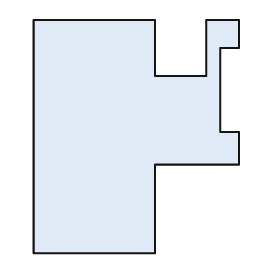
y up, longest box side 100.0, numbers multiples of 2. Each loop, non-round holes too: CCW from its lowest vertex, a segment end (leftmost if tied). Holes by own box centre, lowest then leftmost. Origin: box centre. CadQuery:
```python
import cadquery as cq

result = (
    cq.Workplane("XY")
    .moveTo(-44.0, -50.0)
    .lineTo(8.0, -50.0)
    .lineTo(8.0, -12.0)
    .lineTo(44.0, -12.0)
    .lineTo(44.0, 2.0)
    .lineTo(36.0, 2.0)
    .lineTo(36.0, 38.0)
    .lineTo(44.0, 38.0)
    .lineTo(44.0, 50.0)
    .lineTo(30.0, 50.0)
    .lineTo(30.0, 26.0)
    .lineTo(8.0, 26.0)
    .lineTo(8.0, 50.0)
    .lineTo(-44.0, 50.0)
    .close()
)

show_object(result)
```